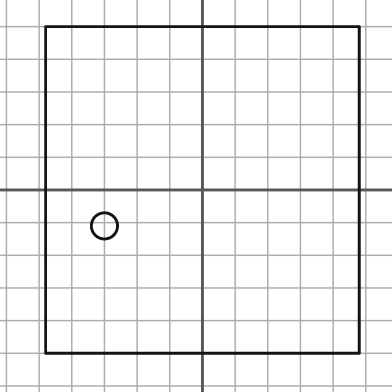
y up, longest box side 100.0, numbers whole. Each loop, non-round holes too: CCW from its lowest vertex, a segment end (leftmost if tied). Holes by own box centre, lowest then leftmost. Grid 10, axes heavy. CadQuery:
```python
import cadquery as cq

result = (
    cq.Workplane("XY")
    .moveTo(-48.0, -50.0)
    .lineTo(48.0, -50.0)
    .lineTo(48.0, 50.0)
    .lineTo(-48.0, 50.0)
    .close()
    .moveTo(-30.0, -11.0)
    .circle(4.0)
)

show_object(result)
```